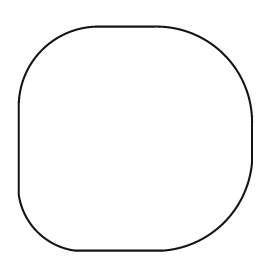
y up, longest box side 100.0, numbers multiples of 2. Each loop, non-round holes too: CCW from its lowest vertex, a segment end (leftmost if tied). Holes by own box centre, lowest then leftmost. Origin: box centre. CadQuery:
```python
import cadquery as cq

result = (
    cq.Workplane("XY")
    .moveTo(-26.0, -48.0)
    .lineTo(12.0, -48.0)
    .threePointArc((38.0, -36.0), (50.0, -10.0))
    .lineTo(50.0, 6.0)
    .threePointArc((38.0, 36.0), (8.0, 48.0))
    .lineTo(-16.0, 48.0)
    .threePointArc((-40.0, 38.0), (-50.0, 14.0))
    .lineTo(-50.0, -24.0)
    .threePointArc((-42.0, -40.0), (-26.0, -48.0))
    .close()
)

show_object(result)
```